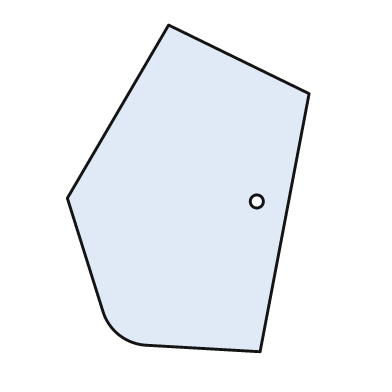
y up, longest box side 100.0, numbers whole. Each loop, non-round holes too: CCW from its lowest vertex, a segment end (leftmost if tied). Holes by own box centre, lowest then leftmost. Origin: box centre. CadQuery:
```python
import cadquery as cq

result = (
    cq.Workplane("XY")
    .moveTo(22.0, -50.0)
    .lineTo(37.0, 29.0)
    .lineTo(-6.0, 50.0)
    .lineTo(-37.0, -3.0)
    .lineTo(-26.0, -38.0)
    .threePointArc((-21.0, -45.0), (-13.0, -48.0))
    .close()
    .moveTo(21.0, -4.0)
    .circle(2.0)
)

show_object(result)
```